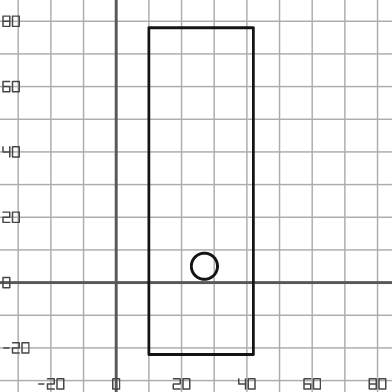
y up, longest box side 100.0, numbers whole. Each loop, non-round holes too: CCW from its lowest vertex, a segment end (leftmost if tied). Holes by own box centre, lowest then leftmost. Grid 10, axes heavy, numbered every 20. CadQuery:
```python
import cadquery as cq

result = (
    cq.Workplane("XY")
    .moveTo(10.0, -22.0)
    .lineTo(42.0, -22.0)
    .lineTo(42.0, 78.0)
    .lineTo(10.0, 78.0)
    .close()
    .moveTo(27.0, 5.0)
    .circle(4.0)
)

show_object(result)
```